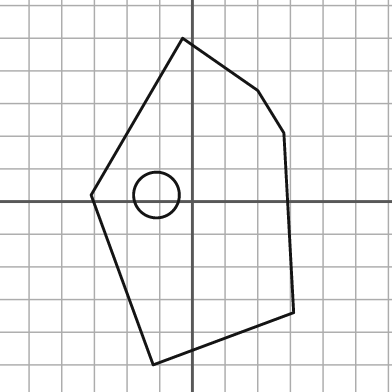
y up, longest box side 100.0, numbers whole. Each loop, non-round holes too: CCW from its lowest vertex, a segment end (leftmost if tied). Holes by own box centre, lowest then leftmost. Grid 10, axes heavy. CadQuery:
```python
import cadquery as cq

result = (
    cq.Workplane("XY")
    .moveTo(-12.0, -50.0)
    .lineTo(31.0, -34.0)
    .lineTo(28.0, 21.0)
    .lineTo(20.0, 34.0)
    .lineTo(-3.0, 50.0)
    .lineTo(-31.0, 2.0)
    .close()
    .moveTo(-11.0, 2.0)
    .circle(7.0)
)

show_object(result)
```